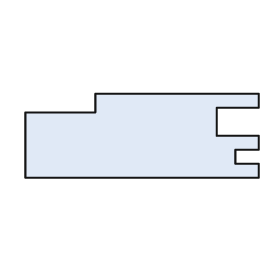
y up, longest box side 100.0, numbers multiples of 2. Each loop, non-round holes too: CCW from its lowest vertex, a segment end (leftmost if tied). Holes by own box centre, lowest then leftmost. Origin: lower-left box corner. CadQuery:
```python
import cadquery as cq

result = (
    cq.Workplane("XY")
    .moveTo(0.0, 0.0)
    .lineTo(100.0, 0.0)
    .lineTo(100.0, 6.0)
    .lineTo(90.0, 6.0)
    .lineTo(90.0, 12.0)
    .lineTo(100.0, 12.0)
    .lineTo(100.0, 18.0)
    .lineTo(82.0, 18.0)
    .lineTo(82.0, 30.0)
    .lineTo(100.0, 30.0)
    .lineTo(100.0, 36.0)
    .lineTo(30.0, 36.0)
    .lineTo(30.0, 28.0)
    .lineTo(0.0, 28.0)
    .close()
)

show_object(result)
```